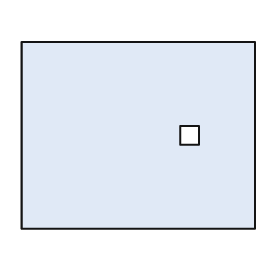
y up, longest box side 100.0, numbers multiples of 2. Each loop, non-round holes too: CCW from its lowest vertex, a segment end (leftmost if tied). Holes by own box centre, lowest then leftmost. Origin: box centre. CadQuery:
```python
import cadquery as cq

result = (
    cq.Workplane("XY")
    .moveTo(-50.0, -40.0)
    .lineTo(50.0, -40.0)
    .lineTo(50.0, 40.0)
    .lineTo(-50.0, 40.0)
    .close()
    .moveTo(18.0, -4.0)
    .lineTo(26.0, -4.0)
    .lineTo(26.0, 4.0)
    .lineTo(18.0, 4.0)
    .close()
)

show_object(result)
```